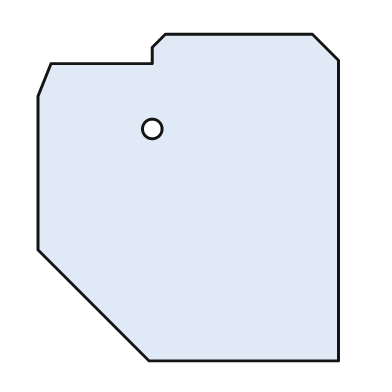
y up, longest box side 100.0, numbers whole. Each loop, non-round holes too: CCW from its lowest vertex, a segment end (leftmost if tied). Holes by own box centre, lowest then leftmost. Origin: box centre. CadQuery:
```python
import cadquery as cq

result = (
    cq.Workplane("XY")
    .moveTo(-12.0, -50.0)
    .lineTo(46.0, -50.0)
    .lineTo(46.0, 42.0)
    .lineTo(38.0, 50.0)
    .lineTo(-7.0, 50.0)
    .lineTo(-11.0, 46.0)
    .lineTo(-11.0, 41.0)
    .lineTo(-42.0, 41.0)
    .lineTo(-46.0, 31.0)
    .lineTo(-46.0, -16.0)
    .close()
    .moveTo(-11.0, 21.0)
    .circle(3.0)
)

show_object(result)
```